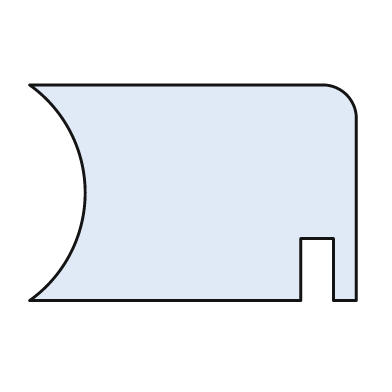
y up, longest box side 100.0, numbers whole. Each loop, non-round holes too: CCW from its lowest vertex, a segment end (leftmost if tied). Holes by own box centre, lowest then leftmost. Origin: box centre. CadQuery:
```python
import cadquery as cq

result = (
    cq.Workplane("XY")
    .moveTo(-50.0, -33.0)
    .lineTo(33.0, -33.0)
    .lineTo(33.0, -14.0)
    .lineTo(43.0, -14.0)
    .lineTo(43.0, -33.0)
    .lineTo(50.0, -33.0)
    .lineTo(50.0, 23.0)
    .threePointArc((47.0, 30.0), (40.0, 33.0))
    .lineTo(-50.0, 33.0)
    .threePointArc((-33.0, 0.0), (-50.0, -33.0))
    .close()
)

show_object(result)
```